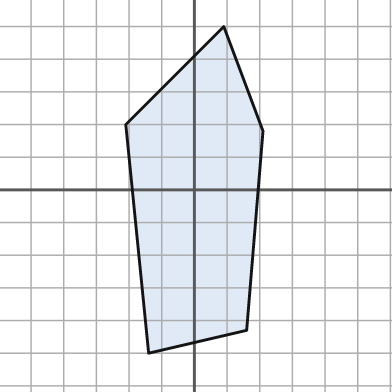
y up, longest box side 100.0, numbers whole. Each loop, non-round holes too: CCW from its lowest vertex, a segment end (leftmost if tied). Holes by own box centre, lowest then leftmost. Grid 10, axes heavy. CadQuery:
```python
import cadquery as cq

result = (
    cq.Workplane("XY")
    .moveTo(-14.0, -50.0)
    .lineTo(16.0, -43.0)
    .lineTo(21.0, 18.0)
    .lineTo(9.0, 50.0)
    .lineTo(-21.0, 20.0)
    .close()
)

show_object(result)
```